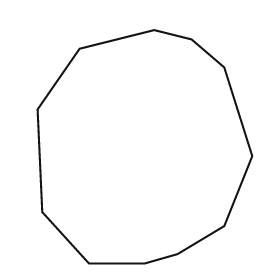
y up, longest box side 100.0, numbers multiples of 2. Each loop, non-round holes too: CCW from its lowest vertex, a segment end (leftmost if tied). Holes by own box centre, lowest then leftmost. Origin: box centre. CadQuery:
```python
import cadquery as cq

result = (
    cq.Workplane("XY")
    .moveTo(-24.0, -50.0)
    .lineTo(0.0, -50.0)
    .lineTo(14.0, -46.0)
    .lineTo(34.0, -34.0)
    .lineTo(46.0, -4.0)
    .lineTo(34.0, 34.0)
    .lineTo(20.0, 46.0)
    .lineTo(4.0, 50.0)
    .lineTo(-28.0, 42.0)
    .lineTo(-46.0, 16.0)
    .lineTo(-44.0, -28.0)
    .close()
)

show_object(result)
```